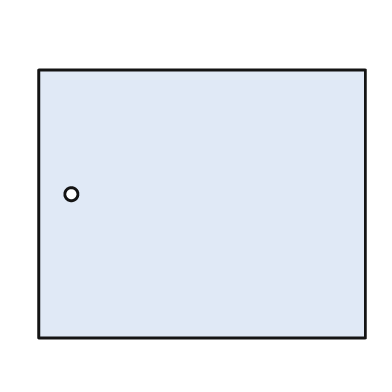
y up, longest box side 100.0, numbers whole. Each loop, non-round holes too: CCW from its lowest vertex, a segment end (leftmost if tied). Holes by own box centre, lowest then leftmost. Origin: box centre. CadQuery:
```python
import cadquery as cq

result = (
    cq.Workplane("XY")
    .moveTo(-50.0, -41.0)
    .lineTo(50.0, -41.0)
    .lineTo(50.0, 41.0)
    .lineTo(-50.0, 41.0)
    .close()
    .moveTo(-40.0, 3.0)
    .circle(2.0)
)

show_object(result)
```